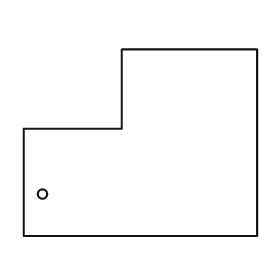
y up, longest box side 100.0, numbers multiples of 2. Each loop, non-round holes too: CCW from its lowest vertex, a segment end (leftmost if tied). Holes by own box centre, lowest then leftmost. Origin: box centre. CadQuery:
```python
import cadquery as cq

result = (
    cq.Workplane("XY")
    .moveTo(-50.0, -40.0)
    .lineTo(50.0, -40.0)
    .lineTo(50.0, 40.0)
    .lineTo(-8.0, 40.0)
    .lineTo(-8.0, 6.0)
    .lineTo(-50.0, 6.0)
    .close()
    .moveTo(-42.0, -22.0)
    .circle(2.0)
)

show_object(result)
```